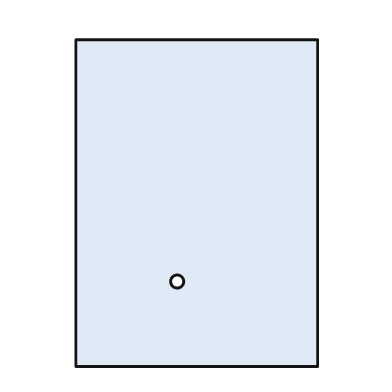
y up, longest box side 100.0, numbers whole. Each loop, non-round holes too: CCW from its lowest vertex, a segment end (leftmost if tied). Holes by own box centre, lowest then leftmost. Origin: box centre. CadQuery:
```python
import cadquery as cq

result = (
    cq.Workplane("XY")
    .moveTo(-37.0, -50.0)
    .lineTo(37.0, -50.0)
    .lineTo(37.0, 50.0)
    .lineTo(-37.0, 50.0)
    .close()
    .moveTo(-6.0, -24.0)
    .circle(2.0)
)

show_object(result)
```